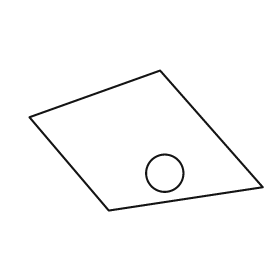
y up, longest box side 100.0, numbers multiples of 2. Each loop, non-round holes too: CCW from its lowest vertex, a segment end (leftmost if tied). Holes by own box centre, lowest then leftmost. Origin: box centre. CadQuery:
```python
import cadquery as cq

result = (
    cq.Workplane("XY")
    .moveTo(-16.0, -30.0)
    .lineTo(50.0, -20.0)
    .lineTo(6.0, 30.0)
    .lineTo(-50.0, 10.0)
    .close()
    .moveTo(8.0, -14.0)
    .circle(8.0)
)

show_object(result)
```